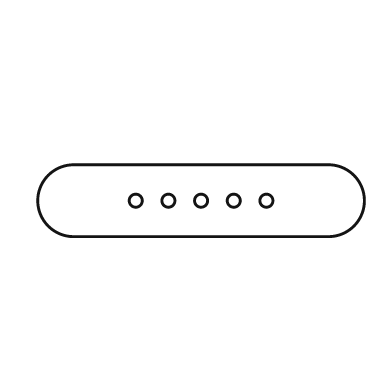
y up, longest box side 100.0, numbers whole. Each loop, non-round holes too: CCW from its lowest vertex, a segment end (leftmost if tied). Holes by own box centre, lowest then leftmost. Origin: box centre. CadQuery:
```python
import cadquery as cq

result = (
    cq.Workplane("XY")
    .moveTo(-39.0, -11.0)
    .lineTo(39.0, -11.0)
    .threePointArc((50.0, 0.0), (39.0, 11.0))
    .lineTo(-39.0, 11.0)
    .threePointArc((-50.0, 0.0), (-39.0, -11.0))
    .close()
    .moveTo(-20.0, 0.0)
    .circle(2.0)
    .moveTo(-10.0, 0.0)
    .circle(2.0)
    .moveTo(0.0, 0.0)
    .circle(2.0)
    .moveTo(10.0, 0.0)
    .circle(2.0)
    .moveTo(20.0, 0.0)
    .circle(2.0)
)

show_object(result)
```